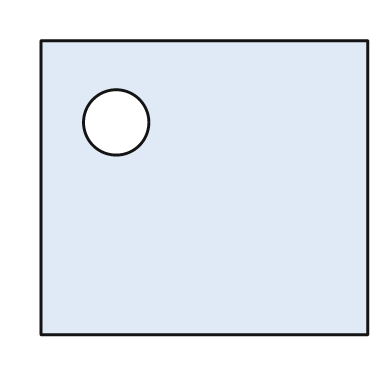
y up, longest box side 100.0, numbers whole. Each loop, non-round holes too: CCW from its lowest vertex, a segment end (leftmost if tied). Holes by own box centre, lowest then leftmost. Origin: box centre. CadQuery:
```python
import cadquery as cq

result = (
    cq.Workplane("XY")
    .moveTo(-50.0, -45.0)
    .lineTo(50.0, -45.0)
    .lineTo(50.0, 45.0)
    .lineTo(-50.0, 45.0)
    .close()
    .moveTo(-27.0, 20.0)
    .circle(10.0)
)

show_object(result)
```